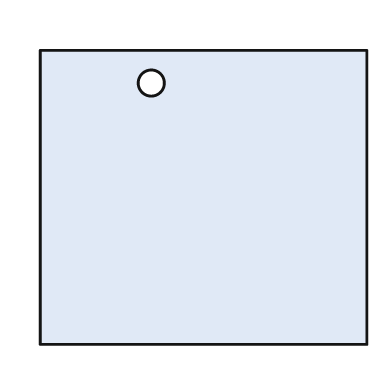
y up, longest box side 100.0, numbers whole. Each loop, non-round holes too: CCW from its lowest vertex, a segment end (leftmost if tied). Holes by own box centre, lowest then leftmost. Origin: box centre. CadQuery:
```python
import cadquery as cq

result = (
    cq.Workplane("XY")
    .moveTo(-50.0, -45.0)
    .lineTo(50.0, -45.0)
    .lineTo(50.0, 45.0)
    .lineTo(-50.0, 45.0)
    .close()
    .moveTo(-16.0, 35.0)
    .circle(4.0)
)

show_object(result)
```